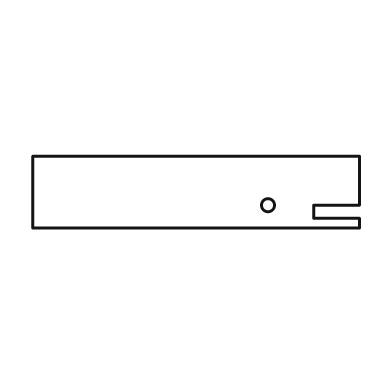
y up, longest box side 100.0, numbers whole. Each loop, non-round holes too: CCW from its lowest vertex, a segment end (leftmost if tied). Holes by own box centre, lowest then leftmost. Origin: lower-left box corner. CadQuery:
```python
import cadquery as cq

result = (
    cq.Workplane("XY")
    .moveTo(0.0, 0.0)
    .lineTo(100.0, 0.0)
    .lineTo(100.0, 3.0)
    .lineTo(86.0, 3.0)
    .lineTo(86.0, 7.0)
    .lineTo(100.0, 7.0)
    .lineTo(100.0, 22.0)
    .lineTo(0.0, 22.0)
    .close()
    .moveTo(72.0, 7.0)
    .circle(2.0)
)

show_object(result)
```